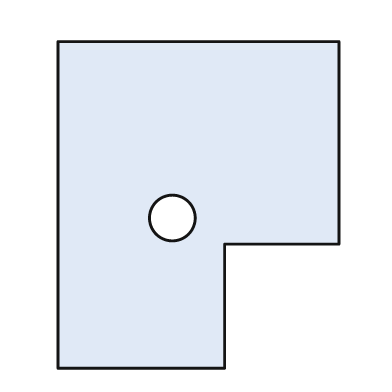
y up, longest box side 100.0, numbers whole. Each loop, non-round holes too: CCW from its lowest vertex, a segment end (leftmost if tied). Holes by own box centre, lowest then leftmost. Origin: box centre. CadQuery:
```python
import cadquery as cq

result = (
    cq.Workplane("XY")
    .moveTo(-43.0, -50.0)
    .lineTo(8.0, -50.0)
    .lineTo(8.0, -12.0)
    .lineTo(43.0, -12.0)
    .lineTo(43.0, 50.0)
    .lineTo(-43.0, 50.0)
    .close()
    .moveTo(-8.0, -4.0)
    .circle(7.0)
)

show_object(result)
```